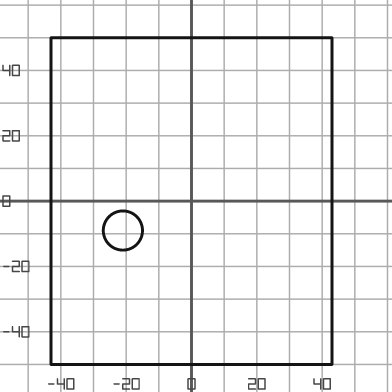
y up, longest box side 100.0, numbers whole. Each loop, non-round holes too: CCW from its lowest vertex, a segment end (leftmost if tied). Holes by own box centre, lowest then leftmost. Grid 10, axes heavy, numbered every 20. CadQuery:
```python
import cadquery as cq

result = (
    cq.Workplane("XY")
    .moveTo(-43.0, -50.0)
    .lineTo(43.0, -50.0)
    .lineTo(43.0, 50.0)
    .lineTo(-43.0, 50.0)
    .close()
    .moveTo(-21.0, -9.0)
    .circle(6.0)
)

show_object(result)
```